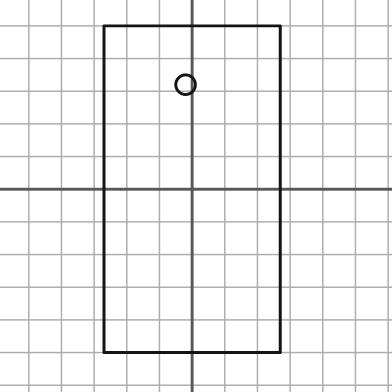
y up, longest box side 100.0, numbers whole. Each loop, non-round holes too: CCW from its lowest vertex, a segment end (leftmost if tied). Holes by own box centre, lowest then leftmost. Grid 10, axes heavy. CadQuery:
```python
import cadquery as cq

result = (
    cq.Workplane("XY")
    .moveTo(-27.0, -50.0)
    .lineTo(27.0, -50.0)
    .lineTo(27.0, 50.0)
    .lineTo(-27.0, 50.0)
    .close()
    .moveTo(-2.0, 32.0)
    .circle(3.0)
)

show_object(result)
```